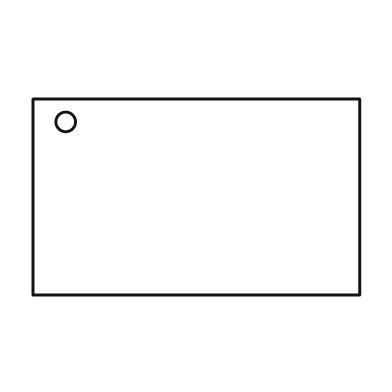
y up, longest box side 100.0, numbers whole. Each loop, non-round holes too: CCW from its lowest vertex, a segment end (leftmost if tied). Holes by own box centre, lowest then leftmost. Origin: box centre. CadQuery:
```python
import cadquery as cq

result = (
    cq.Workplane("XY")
    .moveTo(-50.0, -30.0)
    .lineTo(50.0, -30.0)
    .lineTo(50.0, 30.0)
    .lineTo(-50.0, 30.0)
    .close()
    .moveTo(-40.0, 23.0)
    .circle(3.0)
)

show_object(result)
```